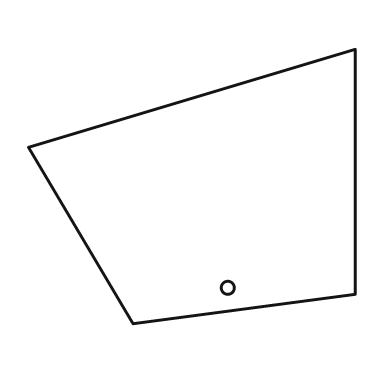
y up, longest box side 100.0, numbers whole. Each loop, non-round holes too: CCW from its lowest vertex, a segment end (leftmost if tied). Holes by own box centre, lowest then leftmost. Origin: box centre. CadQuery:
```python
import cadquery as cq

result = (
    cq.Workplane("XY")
    .moveTo(-18.0, -42.0)
    .lineTo(50.0, -33.0)
    .lineTo(50.0, 42.0)
    .lineTo(-50.0, 12.0)
    .close()
    .moveTo(11.0, -31.0)
    .circle(2.0)
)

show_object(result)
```